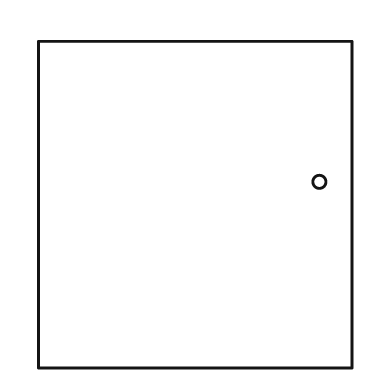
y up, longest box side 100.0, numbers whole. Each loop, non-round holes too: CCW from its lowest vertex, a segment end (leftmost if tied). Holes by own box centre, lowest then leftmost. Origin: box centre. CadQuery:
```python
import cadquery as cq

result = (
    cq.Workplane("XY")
    .moveTo(-48.0, -50.0)
    .lineTo(48.0, -50.0)
    .lineTo(48.0, 50.0)
    .lineTo(-48.0, 50.0)
    .close()
    .moveTo(38.0, 7.0)
    .circle(2.0)
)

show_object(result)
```